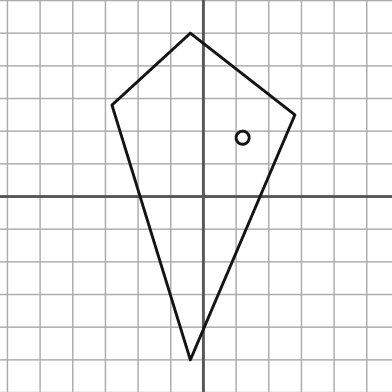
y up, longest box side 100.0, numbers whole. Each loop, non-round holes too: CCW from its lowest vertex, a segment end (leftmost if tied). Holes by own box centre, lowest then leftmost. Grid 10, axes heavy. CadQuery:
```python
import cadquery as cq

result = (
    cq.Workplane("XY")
    .moveTo(-4.0, -50.0)
    .lineTo(28.0, 25.0)
    .lineTo(-4.0, 50.0)
    .lineTo(-28.0, 28.0)
    .close()
    .moveTo(12.0, 18.0)
    .circle(2.0)
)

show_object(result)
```